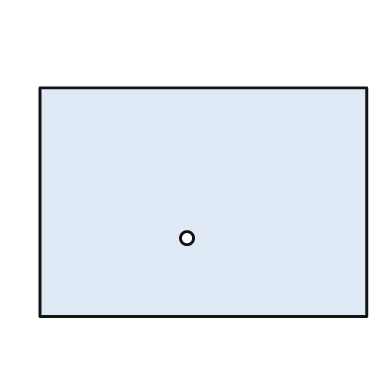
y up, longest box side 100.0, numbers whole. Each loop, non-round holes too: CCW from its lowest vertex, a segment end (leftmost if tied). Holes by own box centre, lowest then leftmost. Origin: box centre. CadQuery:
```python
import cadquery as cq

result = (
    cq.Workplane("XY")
    .moveTo(-50.0, -35.0)
    .lineTo(50.0, -35.0)
    .lineTo(50.0, 35.0)
    .lineTo(-50.0, 35.0)
    .close()
    .moveTo(-5.0, -11.0)
    .circle(2.0)
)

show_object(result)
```